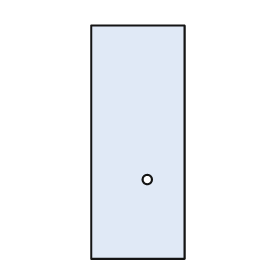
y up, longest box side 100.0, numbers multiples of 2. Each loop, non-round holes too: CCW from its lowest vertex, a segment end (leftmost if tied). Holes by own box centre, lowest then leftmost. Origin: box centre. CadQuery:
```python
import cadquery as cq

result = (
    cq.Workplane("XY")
    .moveTo(-20.0, -50.0)
    .lineTo(20.0, -50.0)
    .lineTo(20.0, 50.0)
    .lineTo(-20.0, 50.0)
    .close()
    .moveTo(4.0, -16.0)
    .circle(2.0)
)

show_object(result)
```